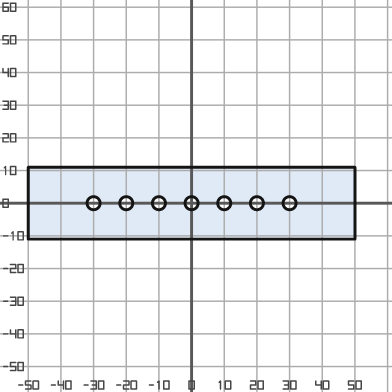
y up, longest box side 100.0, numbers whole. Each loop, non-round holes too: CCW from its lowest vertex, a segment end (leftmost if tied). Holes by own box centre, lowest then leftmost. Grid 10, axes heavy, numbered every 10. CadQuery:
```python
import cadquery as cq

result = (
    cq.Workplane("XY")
    .moveTo(-50.0, -11.0)
    .lineTo(50.0, -11.0)
    .lineTo(50.0, 11.0)
    .lineTo(-50.0, 11.0)
    .close()
    .moveTo(-30.0, 0.0)
    .circle(2.0)
    .moveTo(-20.0, 0.0)
    .circle(2.0)
    .moveTo(-10.0, 0.0)
    .circle(2.0)
    .moveTo(0.0, 0.0)
    .circle(2.0)
    .moveTo(10.0, 0.0)
    .circle(2.0)
    .moveTo(20.0, 0.0)
    .circle(2.0)
    .moveTo(30.0, 0.0)
    .circle(2.0)
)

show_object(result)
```